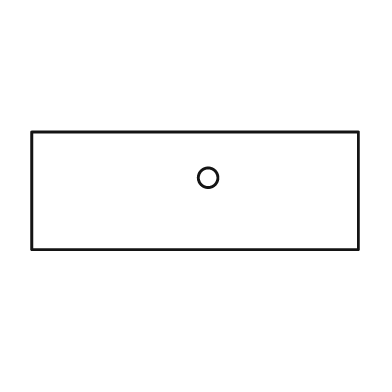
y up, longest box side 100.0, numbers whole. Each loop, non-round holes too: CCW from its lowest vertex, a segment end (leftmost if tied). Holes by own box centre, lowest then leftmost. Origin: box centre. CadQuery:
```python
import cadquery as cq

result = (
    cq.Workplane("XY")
    .moveTo(-50.0, -18.0)
    .lineTo(50.0, -18.0)
    .lineTo(50.0, 18.0)
    .lineTo(-50.0, 18.0)
    .close()
    .moveTo(4.0, 4.0)
    .circle(3.0)
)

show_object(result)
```